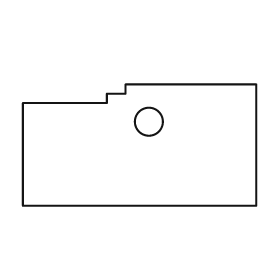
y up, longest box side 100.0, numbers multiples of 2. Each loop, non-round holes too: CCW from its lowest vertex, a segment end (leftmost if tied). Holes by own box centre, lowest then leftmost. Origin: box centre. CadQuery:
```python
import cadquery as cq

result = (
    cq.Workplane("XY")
    .moveTo(-50.0, -26.0)
    .lineTo(50.0, -26.0)
    .lineTo(50.0, 26.0)
    .lineTo(-6.0, 26.0)
    .lineTo(-6.0, 22.0)
    .lineTo(-14.0, 22.0)
    .lineTo(-14.0, 18.0)
    .lineTo(-50.0, 18.0)
    .close()
    .moveTo(4.0, 10.0)
    .circle(6.0)
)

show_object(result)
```